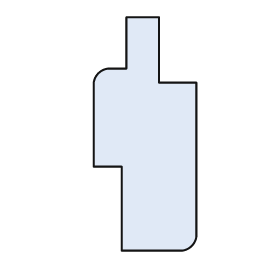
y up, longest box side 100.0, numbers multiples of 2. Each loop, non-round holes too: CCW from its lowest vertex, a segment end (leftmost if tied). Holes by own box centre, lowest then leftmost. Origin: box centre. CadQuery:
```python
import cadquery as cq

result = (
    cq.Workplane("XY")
    .moveTo(-10.0, -50.0)
    .lineTo(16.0, -50.0)
    .threePointArc((20.0, -48.0), (22.0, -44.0))
    .lineTo(22.0, 22.0)
    .lineTo(6.0, 22.0)
    .lineTo(6.0, 50.0)
    .lineTo(-8.0, 50.0)
    .lineTo(-8.0, 28.0)
    .lineTo(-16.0, 28.0)
    .threePointArc((-20.0, 26.0), (-22.0, 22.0))
    .lineTo(-22.0, -14.0)
    .lineTo(-10.0, -14.0)
    .close()
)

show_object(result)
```